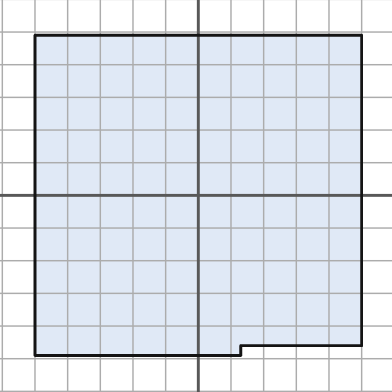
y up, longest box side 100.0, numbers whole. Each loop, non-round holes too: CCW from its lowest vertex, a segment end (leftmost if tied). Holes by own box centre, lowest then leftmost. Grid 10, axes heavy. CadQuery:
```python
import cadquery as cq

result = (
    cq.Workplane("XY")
    .moveTo(-50.0, -49.0)
    .lineTo(13.0, -49.0)
    .lineTo(13.0, -46.0)
    .lineTo(50.0, -46.0)
    .lineTo(50.0, 49.0)
    .lineTo(-50.0, 49.0)
    .close()
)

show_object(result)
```